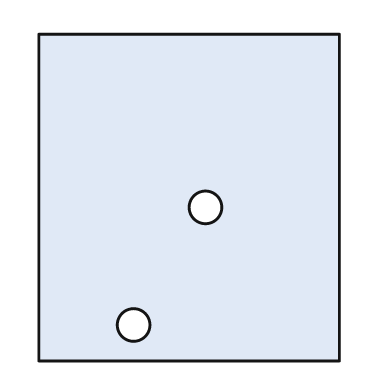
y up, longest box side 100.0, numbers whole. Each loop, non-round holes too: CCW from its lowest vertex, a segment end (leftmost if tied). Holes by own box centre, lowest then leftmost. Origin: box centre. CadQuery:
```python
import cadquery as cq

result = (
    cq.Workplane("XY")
    .moveTo(-46.0, -50.0)
    .lineTo(46.0, -50.0)
    .lineTo(46.0, 50.0)
    .lineTo(-46.0, 50.0)
    .close()
    .moveTo(-17.0, -39.0)
    .circle(5.0)
    .moveTo(5.0, -3.0)
    .circle(5.0)
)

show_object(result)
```